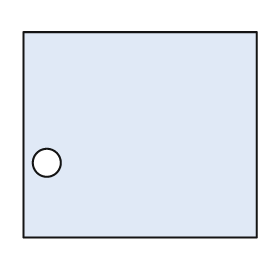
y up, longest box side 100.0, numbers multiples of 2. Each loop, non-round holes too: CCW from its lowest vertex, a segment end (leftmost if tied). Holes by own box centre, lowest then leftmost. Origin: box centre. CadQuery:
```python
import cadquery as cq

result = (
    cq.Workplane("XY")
    .moveTo(-50.0, -44.0)
    .lineTo(50.0, -44.0)
    .lineTo(50.0, 44.0)
    .lineTo(-50.0, 44.0)
    .close()
    .moveTo(-40.0, -12.0)
    .circle(6.0)
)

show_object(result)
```